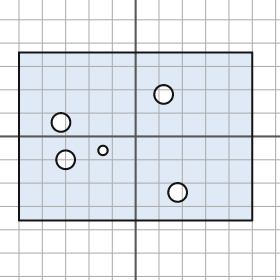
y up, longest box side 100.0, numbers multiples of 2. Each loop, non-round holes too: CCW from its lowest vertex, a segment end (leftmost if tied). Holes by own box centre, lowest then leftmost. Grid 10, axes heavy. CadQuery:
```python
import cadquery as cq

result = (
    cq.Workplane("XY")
    .moveTo(-50.0, -36.0)
    .lineTo(50.0, -36.0)
    .lineTo(50.0, 36.0)
    .lineTo(-50.0, 36.0)
    .close()
    .moveTo(18.0, -24.0)
    .circle(4.0)
    .moveTo(-30.0, -10.0)
    .circle(4.0)
    .moveTo(-14.0, -6.0)
    .circle(2.0)
    .moveTo(-32.0, 6.0)
    .circle(4.0)
    .moveTo(12.0, 18.0)
    .circle(4.0)
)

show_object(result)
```